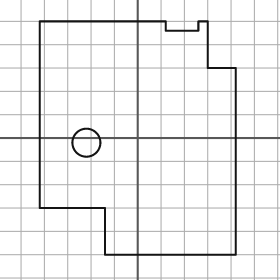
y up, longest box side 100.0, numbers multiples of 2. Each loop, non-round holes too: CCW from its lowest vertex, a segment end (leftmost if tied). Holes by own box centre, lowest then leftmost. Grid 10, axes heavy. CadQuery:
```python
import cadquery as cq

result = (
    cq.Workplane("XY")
    .moveTo(-14.0, -50.0)
    .lineTo(42.0, -50.0)
    .lineTo(42.0, 30.0)
    .lineTo(30.0, 30.0)
    .lineTo(30.0, 50.0)
    .lineTo(26.0, 50.0)
    .lineTo(26.0, 46.0)
    .lineTo(12.0, 46.0)
    .lineTo(12.0, 50.0)
    .lineTo(-42.0, 50.0)
    .lineTo(-42.0, -30.0)
    .lineTo(-14.0, -30.0)
    .close()
    .moveTo(-22.0, -2.0)
    .circle(6.0)
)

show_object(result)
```